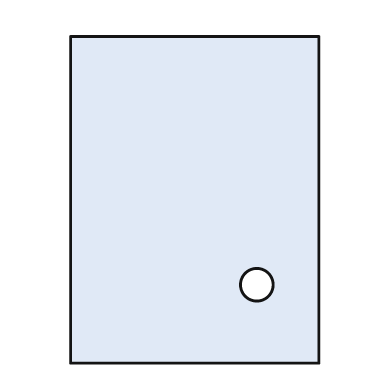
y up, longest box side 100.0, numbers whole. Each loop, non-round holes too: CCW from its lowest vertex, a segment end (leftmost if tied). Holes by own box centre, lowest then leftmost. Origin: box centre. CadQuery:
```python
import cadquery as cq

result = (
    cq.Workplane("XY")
    .moveTo(-38.0, -50.0)
    .lineTo(38.0, -50.0)
    .lineTo(38.0, 50.0)
    .lineTo(-38.0, 50.0)
    .close()
    .moveTo(19.0, -26.0)
    .circle(5.0)
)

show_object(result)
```